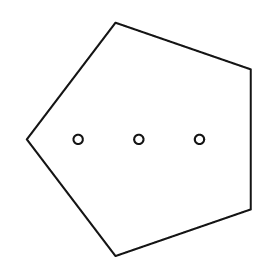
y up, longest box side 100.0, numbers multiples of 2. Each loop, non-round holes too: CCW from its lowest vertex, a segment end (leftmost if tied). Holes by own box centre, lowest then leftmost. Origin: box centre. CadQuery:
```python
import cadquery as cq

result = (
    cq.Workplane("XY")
    .moveTo(-10.0, -50.0)
    .lineTo(48.0, -30.0)
    .lineTo(48.0, 30.0)
    .lineTo(-10.0, 50.0)
    .lineTo(-48.0, 0.0)
    .close()
    .moveTo(-26.0, 0.0)
    .circle(2.0)
    .moveTo(0.0, 0.0)
    .circle(2.0)
    .moveTo(26.0, 0.0)
    .circle(2.0)
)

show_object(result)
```